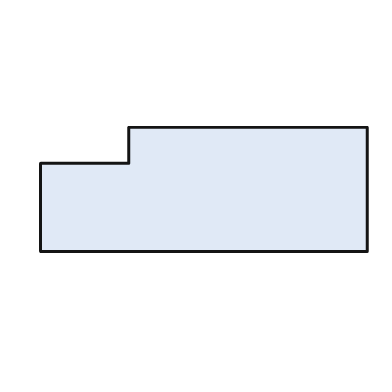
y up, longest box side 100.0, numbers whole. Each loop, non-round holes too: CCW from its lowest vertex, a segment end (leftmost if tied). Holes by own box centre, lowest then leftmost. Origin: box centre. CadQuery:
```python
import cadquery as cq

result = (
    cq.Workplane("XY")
    .moveTo(-50.0, -19.0)
    .lineTo(50.0, -19.0)
    .lineTo(50.0, 19.0)
    .lineTo(-23.0, 19.0)
    .lineTo(-23.0, 8.0)
    .lineTo(-50.0, 8.0)
    .close()
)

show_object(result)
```